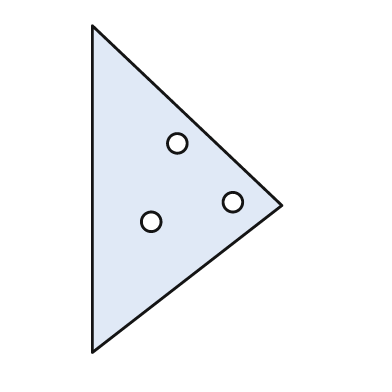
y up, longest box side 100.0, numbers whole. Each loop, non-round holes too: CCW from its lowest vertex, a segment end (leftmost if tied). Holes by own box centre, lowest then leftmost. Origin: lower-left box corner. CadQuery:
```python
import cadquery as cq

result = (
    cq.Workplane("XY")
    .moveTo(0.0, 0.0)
    .lineTo(58.0, 45.0)
    .lineTo(0.0, 100.0)
    .close()
    .moveTo(18.0, 40.0)
    .circle(3.0)
    .moveTo(43.0, 46.0)
    .circle(3.0)
    .moveTo(26.0, 64.0)
    .circle(3.0)
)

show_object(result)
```